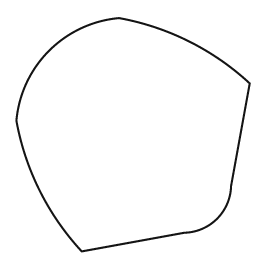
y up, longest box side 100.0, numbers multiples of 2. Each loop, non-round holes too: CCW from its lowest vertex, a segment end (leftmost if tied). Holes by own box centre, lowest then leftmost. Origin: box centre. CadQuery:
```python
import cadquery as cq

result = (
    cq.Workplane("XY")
    .moveTo(-22.0, -50.0)
    .lineTo(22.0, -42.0)
    .threePointArc((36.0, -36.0), (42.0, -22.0))
    .lineTo(50.0, 22.0)
    .threePointArc((24.0, 40.0), (-6.0, 50.0))
    .threePointArc((-36.0, 36.0), (-50.0, 6.0))
    .threePointArc((-40.0, -24.0), (-22.0, -50.0))
    .close()
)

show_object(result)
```